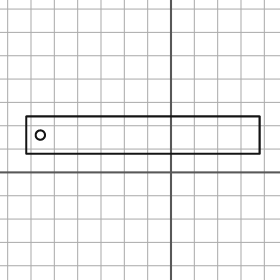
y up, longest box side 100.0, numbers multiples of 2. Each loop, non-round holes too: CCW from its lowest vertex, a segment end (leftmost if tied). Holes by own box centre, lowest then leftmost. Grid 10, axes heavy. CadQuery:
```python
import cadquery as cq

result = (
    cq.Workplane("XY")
    .moveTo(-62.0, 8.0)
    .lineTo(38.0, 8.0)
    .lineTo(38.0, 24.0)
    .lineTo(-62.0, 24.0)
    .close()
    .moveTo(-56.0, 16.0)
    .circle(2.0)
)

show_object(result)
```